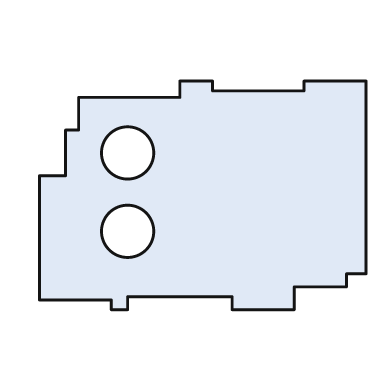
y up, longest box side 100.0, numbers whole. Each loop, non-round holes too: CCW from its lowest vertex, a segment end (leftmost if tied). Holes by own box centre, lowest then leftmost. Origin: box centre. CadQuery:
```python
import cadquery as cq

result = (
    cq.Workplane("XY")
    .moveTo(-28.0, -35.0)
    .lineTo(-23.0, -35.0)
    .lineTo(-23.0, -31.0)
    .lineTo(9.0, -31.0)
    .lineTo(9.0, -35.0)
    .lineTo(28.0, -35.0)
    .lineTo(28.0, -28.0)
    .lineTo(44.0, -28.0)
    .lineTo(44.0, -24.0)
    .lineTo(50.0, -24.0)
    .lineTo(50.0, 35.0)
    .lineTo(31.0, 35.0)
    .lineTo(31.0, 32.0)
    .lineTo(3.0, 32.0)
    .lineTo(3.0, 35.0)
    .lineTo(-7.0, 35.0)
    .lineTo(-7.0, 30.0)
    .lineTo(-38.0, 30.0)
    .lineTo(-38.0, 20.0)
    .lineTo(-42.0, 20.0)
    .lineTo(-42.0, 6.0)
    .lineTo(-50.0, 6.0)
    .lineTo(-50.0, -32.0)
    .lineTo(-28.0, -32.0)
    .close()
    .moveTo(-23.0, -11.0)
    .circle(8.0)
    .moveTo(-23.0, 13.0)
    .circle(8.0)
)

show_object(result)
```